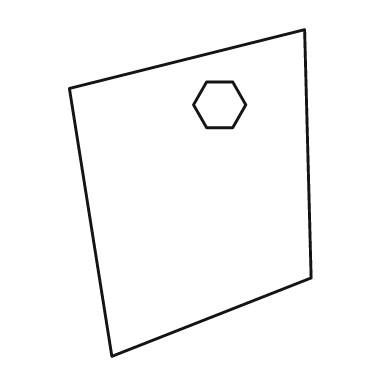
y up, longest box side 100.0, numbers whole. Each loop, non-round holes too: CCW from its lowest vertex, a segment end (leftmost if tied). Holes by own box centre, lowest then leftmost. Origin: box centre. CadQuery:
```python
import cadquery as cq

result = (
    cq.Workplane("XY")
    .moveTo(-24.0, -50.0)
    .lineTo(37.0, -26.0)
    .lineTo(35.0, 50.0)
    .lineTo(-37.0, 32.0)
    .close()
    .moveTo(5.0, 20.0)
    .lineTo(13.0, 20.0)
    .lineTo(17.0, 27.0)
    .lineTo(13.0, 34.0)
    .lineTo(5.0, 34.0)
    .lineTo(1.0, 27.0)
    .close()
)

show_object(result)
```